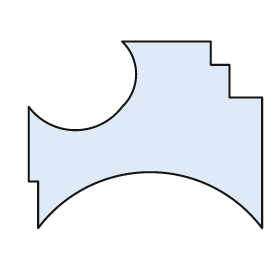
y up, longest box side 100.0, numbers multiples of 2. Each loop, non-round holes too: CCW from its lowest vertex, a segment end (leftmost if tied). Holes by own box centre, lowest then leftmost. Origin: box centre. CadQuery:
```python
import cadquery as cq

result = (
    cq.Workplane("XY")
    .moveTo(-46.0, -40.0)
    .threePointArc((2.0, -16.0), (50.0, -40.0))
    .lineTo(50.0, 16.0)
    .lineTo(36.0, 16.0)
    .lineTo(36.0, 30.0)
    .lineTo(28.0, 30.0)
    .lineTo(28.0, 40.0)
    .lineTo(-10.0, 40.0)
    .threePointArc((-4.0, 26.0), (-10.0, 12.0))
    .threePointArc((-30.0, 2.0), (-50.0, 12.0))
    .lineTo(-50.0, -20.0)
    .lineTo(-46.0, -20.0)
    .close()
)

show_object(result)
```